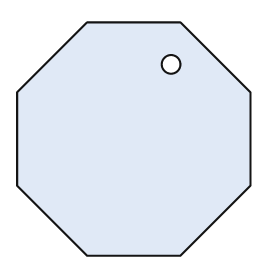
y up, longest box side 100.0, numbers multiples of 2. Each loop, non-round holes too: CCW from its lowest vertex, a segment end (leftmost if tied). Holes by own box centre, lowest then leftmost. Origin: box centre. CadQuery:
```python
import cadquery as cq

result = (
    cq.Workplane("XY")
    .moveTo(-20.0, -50.0)
    .lineTo(20.0, -50.0)
    .lineTo(50.0, -20.0)
    .lineTo(50.0, 20.0)
    .lineTo(20.0, 50.0)
    .lineTo(-20.0, 50.0)
    .lineTo(-50.0, 20.0)
    .lineTo(-50.0, -20.0)
    .close()
    .moveTo(16.0, 32.0)
    .circle(4.0)
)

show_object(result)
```